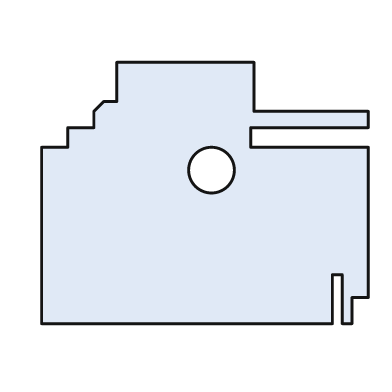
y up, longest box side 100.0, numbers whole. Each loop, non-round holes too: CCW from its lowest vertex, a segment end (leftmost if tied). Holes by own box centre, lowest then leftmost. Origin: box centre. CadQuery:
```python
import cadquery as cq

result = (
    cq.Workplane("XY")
    .moveTo(-50.0, -40.0)
    .lineTo(39.0, -40.0)
    .lineTo(39.0, -25.0)
    .lineTo(42.0, -25.0)
    .lineTo(42.0, -40.0)
    .lineTo(45.0, -40.0)
    .lineTo(45.0, -32.0)
    .lineTo(50.0, -32.0)
    .lineTo(50.0, 14.0)
    .lineTo(14.0, 14.0)
    .lineTo(14.0, 20.0)
    .lineTo(50.0, 20.0)
    .lineTo(50.0, 25.0)
    .lineTo(15.0, 25.0)
    .lineTo(15.0, 40.0)
    .lineTo(-27.0, 40.0)
    .lineTo(-27.0, 28.0)
    .lineTo(-31.0, 28.0)
    .lineTo(-34.0, 25.0)
    .lineTo(-34.0, 20.0)
    .lineTo(-42.0, 20.0)
    .lineTo(-42.0, 14.0)
    .lineTo(-50.0, 14.0)
    .close()
    .moveTo(2.0, 7.0)
    .circle(7.0)
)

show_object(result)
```